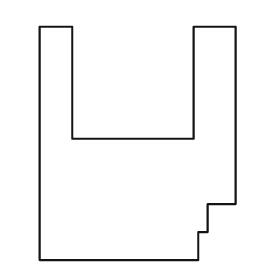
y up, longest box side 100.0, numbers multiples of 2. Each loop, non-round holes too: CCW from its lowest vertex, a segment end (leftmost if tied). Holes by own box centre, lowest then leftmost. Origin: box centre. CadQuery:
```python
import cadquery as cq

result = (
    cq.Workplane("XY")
    .moveTo(-42.0, -50.0)
    .lineTo(26.0, -50.0)
    .lineTo(26.0, -38.0)
    .lineTo(30.0, -38.0)
    .lineTo(30.0, -26.0)
    .lineTo(42.0, -26.0)
    .lineTo(42.0, 50.0)
    .lineTo(24.0, 50.0)
    .lineTo(24.0, 2.0)
    .lineTo(-28.0, 2.0)
    .lineTo(-28.0, 50.0)
    .lineTo(-42.0, 50.0)
    .close()
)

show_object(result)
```